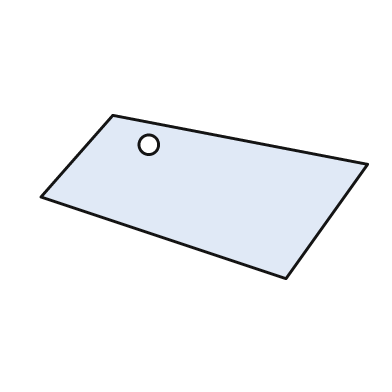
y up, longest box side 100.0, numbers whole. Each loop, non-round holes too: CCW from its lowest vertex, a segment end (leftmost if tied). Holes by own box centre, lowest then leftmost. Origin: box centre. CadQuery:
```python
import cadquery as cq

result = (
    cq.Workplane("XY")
    .moveTo(25.0, -25.0)
    .lineTo(50.0, 10.0)
    .lineTo(-28.0, 25.0)
    .lineTo(-50.0, 0.0)
    .close()
    .moveTo(-17.0, 16.0)
    .circle(3.0)
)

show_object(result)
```